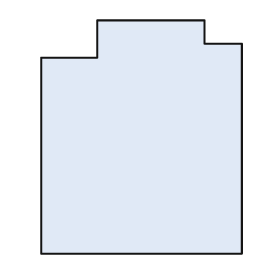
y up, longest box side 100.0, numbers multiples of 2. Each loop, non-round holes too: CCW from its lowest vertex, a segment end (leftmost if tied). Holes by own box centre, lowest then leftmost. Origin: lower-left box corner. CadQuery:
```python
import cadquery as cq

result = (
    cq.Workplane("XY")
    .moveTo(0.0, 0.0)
    .lineTo(86.0, 0.0)
    .lineTo(86.0, 90.0)
    .lineTo(70.0, 90.0)
    .lineTo(70.0, 100.0)
    .lineTo(24.0, 100.0)
    .lineTo(24.0, 84.0)
    .lineTo(0.0, 84.0)
    .close()
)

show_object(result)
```